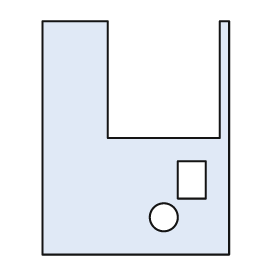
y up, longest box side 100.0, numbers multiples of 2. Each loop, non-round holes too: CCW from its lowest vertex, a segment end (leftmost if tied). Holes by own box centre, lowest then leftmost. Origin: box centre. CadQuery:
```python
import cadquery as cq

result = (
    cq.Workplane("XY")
    .moveTo(-40.0, -50.0)
    .lineTo(40.0, -50.0)
    .lineTo(40.0, 50.0)
    .lineTo(36.0, 50.0)
    .lineTo(36.0, 0.0)
    .lineTo(-12.0, 0.0)
    .lineTo(-12.0, 50.0)
    .lineTo(-40.0, 50.0)
    .close()
    .moveTo(12.0, -34.0)
    .circle(6.0)
    .moveTo(18.0, -26.0)
    .lineTo(30.0, -26.0)
    .lineTo(30.0, -10.0)
    .lineTo(18.0, -10.0)
    .close()
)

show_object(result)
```